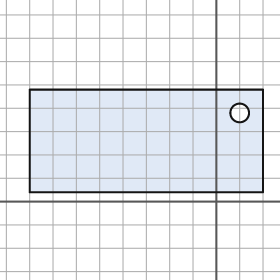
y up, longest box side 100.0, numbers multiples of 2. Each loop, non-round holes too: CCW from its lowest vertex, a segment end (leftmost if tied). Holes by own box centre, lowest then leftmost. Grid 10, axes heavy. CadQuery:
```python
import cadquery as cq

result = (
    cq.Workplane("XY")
    .moveTo(-80.0, 4.0)
    .lineTo(20.0, 4.0)
    .lineTo(20.0, 48.0)
    .lineTo(-80.0, 48.0)
    .close()
    .moveTo(10.0, 38.0)
    .circle(4.0)
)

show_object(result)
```